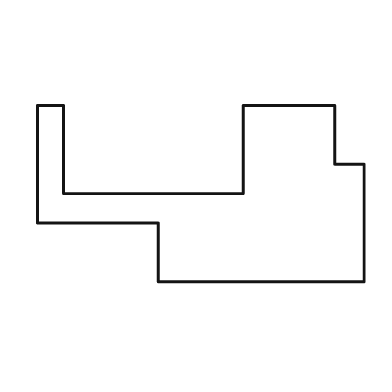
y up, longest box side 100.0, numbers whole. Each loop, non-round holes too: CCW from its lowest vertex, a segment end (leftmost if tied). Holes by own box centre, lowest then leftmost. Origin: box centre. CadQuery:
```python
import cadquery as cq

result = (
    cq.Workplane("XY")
    .moveTo(-13.0, -27.0)
    .lineTo(50.0, -27.0)
    .lineTo(50.0, 9.0)
    .lineTo(41.0, 9.0)
    .lineTo(41.0, 27.0)
    .lineTo(13.0, 27.0)
    .lineTo(13.0, 0.0)
    .lineTo(-42.0, 0.0)
    .lineTo(-42.0, 27.0)
    .lineTo(-50.0, 27.0)
    .lineTo(-50.0, -9.0)
    .lineTo(-13.0, -9.0)
    .close()
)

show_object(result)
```